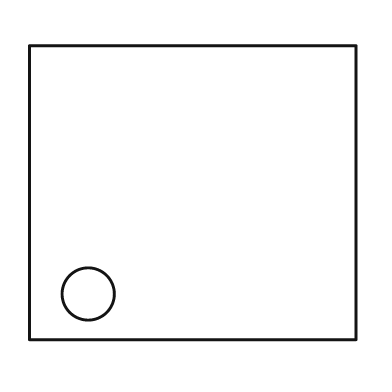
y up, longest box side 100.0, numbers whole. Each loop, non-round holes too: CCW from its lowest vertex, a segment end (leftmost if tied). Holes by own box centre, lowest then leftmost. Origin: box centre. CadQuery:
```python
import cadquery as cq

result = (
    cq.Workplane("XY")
    .moveTo(-50.0, -45.0)
    .lineTo(50.0, -45.0)
    .lineTo(50.0, 45.0)
    .lineTo(-50.0, 45.0)
    .close()
    .moveTo(-32.0, -31.0)
    .circle(8.0)
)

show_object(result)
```